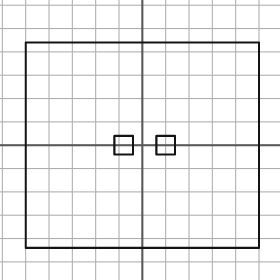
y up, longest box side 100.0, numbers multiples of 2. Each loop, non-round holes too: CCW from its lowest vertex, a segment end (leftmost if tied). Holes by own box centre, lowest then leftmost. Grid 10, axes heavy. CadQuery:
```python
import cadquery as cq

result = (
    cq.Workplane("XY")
    .moveTo(-50.0, -44.0)
    .lineTo(50.0, -44.0)
    .lineTo(50.0, 44.0)
    .lineTo(-50.0, 44.0)
    .close()
    .moveTo(-12.0, -4.0)
    .lineTo(-4.0, -4.0)
    .lineTo(-4.0, 4.0)
    .lineTo(-12.0, 4.0)
    .close()
    .moveTo(6.0, -4.0)
    .lineTo(14.0, -4.0)
    .lineTo(14.0, 4.0)
    .lineTo(6.0, 4.0)
    .close()
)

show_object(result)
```